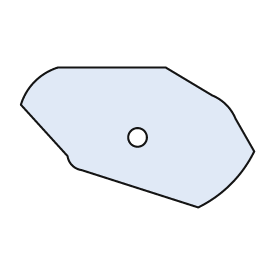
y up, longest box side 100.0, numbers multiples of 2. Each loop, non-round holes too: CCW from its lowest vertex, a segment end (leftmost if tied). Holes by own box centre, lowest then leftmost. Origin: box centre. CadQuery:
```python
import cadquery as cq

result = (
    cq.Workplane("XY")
    .moveTo(26.0, -30.0)
    .threePointArc((40.0, -20.0), (50.0, -6.0))
    .lineTo(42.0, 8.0)
    .threePointArc((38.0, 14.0), (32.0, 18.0))
    .lineTo(12.0, 30.0)
    .lineTo(-34.0, 30.0)
    .threePointArc((-44.0, 24.0), (-50.0, 14.0))
    .lineTo(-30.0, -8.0)
    .threePointArc((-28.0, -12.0), (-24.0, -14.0))
    .close()
    .moveTo(0.0, 0.0)
    .circle(4.0)
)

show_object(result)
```